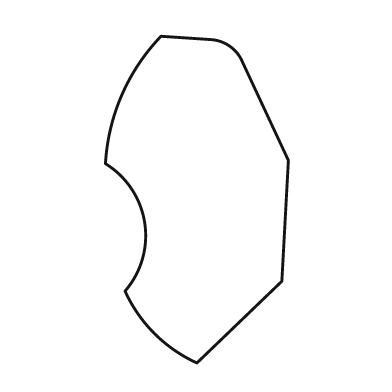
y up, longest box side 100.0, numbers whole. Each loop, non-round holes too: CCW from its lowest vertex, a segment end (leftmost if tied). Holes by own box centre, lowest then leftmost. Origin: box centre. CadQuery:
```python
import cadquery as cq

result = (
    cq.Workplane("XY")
    .moveTo(0.0, -50.0)
    .lineTo(26.0, -25.0)
    .lineTo(28.0, 12.0)
    .lineTo(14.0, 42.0)
    .threePointArc((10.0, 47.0), (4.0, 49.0))
    .lineTo(-11.0, 50.0)
    .threePointArc((-23.0, 32.0), (-28.0, 11.0))
    .threePointArc((-16.0, -7.0), (-22.0, -28.0))
    .threePointArc((-13.0, -41.0), (0.0, -50.0))
    .close()
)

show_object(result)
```